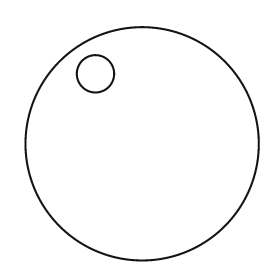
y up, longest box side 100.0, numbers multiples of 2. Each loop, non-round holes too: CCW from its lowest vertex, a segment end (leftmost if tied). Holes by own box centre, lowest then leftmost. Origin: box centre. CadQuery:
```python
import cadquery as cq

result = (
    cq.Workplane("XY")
    .moveTo(0.0, 0.0)
    .circle(50.0)
    .moveTo(-20.0, 30.0)
    .circle(8.0)
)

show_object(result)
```